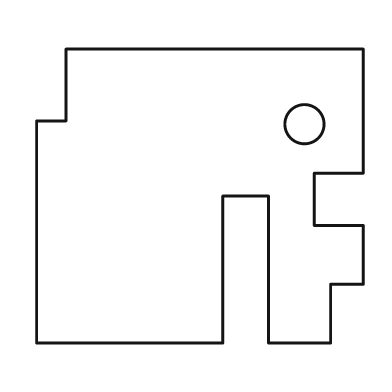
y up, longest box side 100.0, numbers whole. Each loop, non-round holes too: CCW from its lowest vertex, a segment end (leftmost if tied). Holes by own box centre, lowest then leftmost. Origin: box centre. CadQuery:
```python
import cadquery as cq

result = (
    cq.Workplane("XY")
    .moveTo(-50.0, -45.0)
    .lineTo(7.0, -45.0)
    .lineTo(7.0, 0.0)
    .lineTo(21.0, 0.0)
    .lineTo(21.0, -45.0)
    .lineTo(40.0, -45.0)
    .lineTo(40.0, -27.0)
    .lineTo(50.0, -27.0)
    .lineTo(50.0, -9.0)
    .lineTo(35.0, -9.0)
    .lineTo(35.0, 7.0)
    .lineTo(50.0, 7.0)
    .lineTo(50.0, 45.0)
    .lineTo(-41.0, 45.0)
    .lineTo(-41.0, 23.0)
    .lineTo(-50.0, 23.0)
    .close()
    .moveTo(32.0, 22.0)
    .circle(6.0)
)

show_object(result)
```